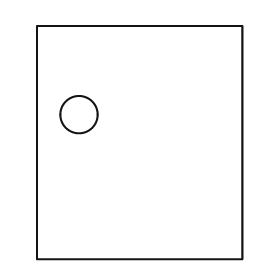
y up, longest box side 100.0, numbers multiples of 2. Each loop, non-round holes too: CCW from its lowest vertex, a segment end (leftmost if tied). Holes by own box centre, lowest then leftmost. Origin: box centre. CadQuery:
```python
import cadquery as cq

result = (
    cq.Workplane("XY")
    .moveTo(-44.0, -50.0)
    .lineTo(44.0, -50.0)
    .lineTo(44.0, 50.0)
    .lineTo(-44.0, 50.0)
    .close()
    .moveTo(-26.0, 12.0)
    .circle(8.0)
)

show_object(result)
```